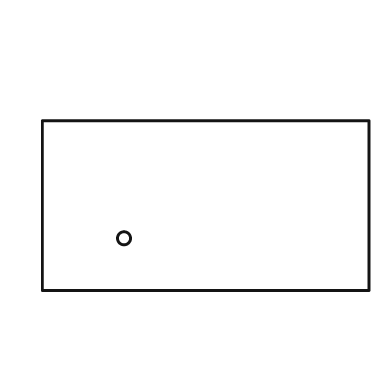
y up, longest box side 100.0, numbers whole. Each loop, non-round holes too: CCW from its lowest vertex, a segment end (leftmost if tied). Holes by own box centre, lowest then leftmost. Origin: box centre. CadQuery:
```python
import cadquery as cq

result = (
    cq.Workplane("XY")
    .moveTo(-50.0, -26.0)
    .lineTo(50.0, -26.0)
    .lineTo(50.0, 26.0)
    .lineTo(-50.0, 26.0)
    .close()
    .moveTo(-25.0, -10.0)
    .circle(2.0)
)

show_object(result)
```